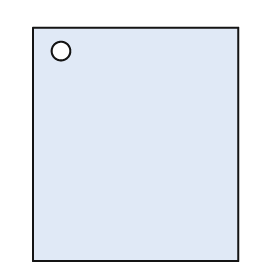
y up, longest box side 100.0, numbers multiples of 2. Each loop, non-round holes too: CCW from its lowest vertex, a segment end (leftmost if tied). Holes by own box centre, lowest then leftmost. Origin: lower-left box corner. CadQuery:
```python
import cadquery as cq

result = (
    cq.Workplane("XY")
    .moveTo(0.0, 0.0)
    .lineTo(88.0, 0.0)
    .lineTo(88.0, 100.0)
    .lineTo(0.0, 100.0)
    .close()
    .moveTo(12.0, 90.0)
    .circle(4.0)
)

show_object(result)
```